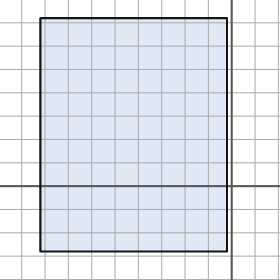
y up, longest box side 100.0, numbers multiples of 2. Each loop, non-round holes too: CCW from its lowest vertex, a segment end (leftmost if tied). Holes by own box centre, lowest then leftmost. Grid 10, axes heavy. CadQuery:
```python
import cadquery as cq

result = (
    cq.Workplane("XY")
    .moveTo(-82.0, -28.0)
    .lineTo(-2.0, -28.0)
    .lineTo(-2.0, 72.0)
    .lineTo(-82.0, 72.0)
    .close()
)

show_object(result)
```